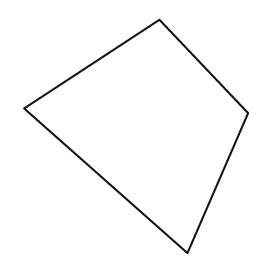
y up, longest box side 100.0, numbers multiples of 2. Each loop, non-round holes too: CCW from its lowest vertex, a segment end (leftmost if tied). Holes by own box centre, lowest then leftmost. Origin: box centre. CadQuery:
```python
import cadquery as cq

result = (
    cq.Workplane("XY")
    .moveTo(22.0, -50.0)
    .lineTo(48.0, 10.0)
    .lineTo(10.0, 50.0)
    .lineTo(-48.0, 12.0)
    .close()
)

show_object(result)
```